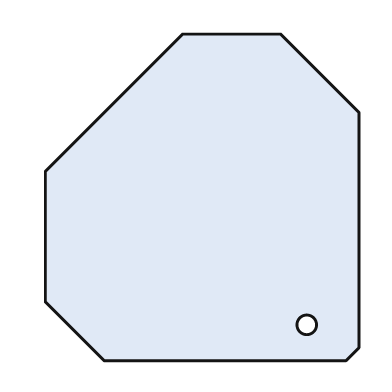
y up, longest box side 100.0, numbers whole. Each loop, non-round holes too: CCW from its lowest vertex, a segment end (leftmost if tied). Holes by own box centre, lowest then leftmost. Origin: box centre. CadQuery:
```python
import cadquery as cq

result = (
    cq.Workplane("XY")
    .moveTo(-30.0, -50.0)
    .lineTo(44.0, -50.0)
    .lineTo(48.0, -46.0)
    .lineTo(48.0, 26.0)
    .lineTo(24.0, 50.0)
    .lineTo(-6.0, 50.0)
    .lineTo(-48.0, 8.0)
    .lineTo(-48.0, -32.0)
    .close()
    .moveTo(32.0, -39.0)
    .circle(3.0)
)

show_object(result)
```